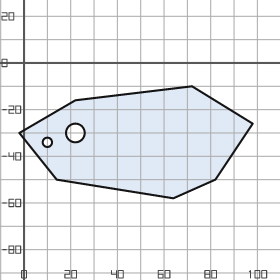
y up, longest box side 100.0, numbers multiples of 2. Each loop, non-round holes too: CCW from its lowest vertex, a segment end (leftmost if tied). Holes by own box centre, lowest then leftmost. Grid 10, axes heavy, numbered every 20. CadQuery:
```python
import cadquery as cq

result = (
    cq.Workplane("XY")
    .moveTo(64.0, -58.0)
    .lineTo(82.0, -50.0)
    .lineTo(98.0, -26.0)
    .lineTo(72.0, -10.0)
    .lineTo(22.0, -16.0)
    .lineTo(-2.0, -30.0)
    .lineTo(14.0, -50.0)
    .close()
    .moveTo(10.0, -34.0)
    .circle(2.0)
    .moveTo(22.0, -30.0)
    .circle(4.0)
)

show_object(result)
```